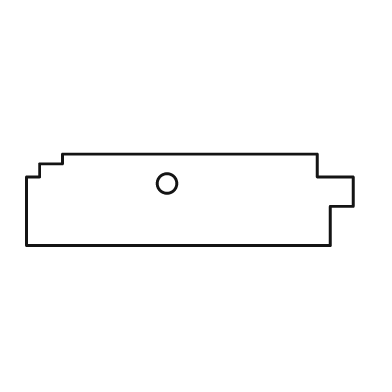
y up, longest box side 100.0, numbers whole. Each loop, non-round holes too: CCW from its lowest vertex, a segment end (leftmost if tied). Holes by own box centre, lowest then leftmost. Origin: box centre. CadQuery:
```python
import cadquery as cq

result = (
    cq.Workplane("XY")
    .moveTo(-50.0, -14.0)
    .lineTo(43.0, -14.0)
    .lineTo(43.0, -2.0)
    .lineTo(50.0, -2.0)
    .lineTo(50.0, 7.0)
    .lineTo(39.0, 7.0)
    .lineTo(39.0, 14.0)
    .lineTo(-39.0, 14.0)
    .lineTo(-39.0, 11.0)
    .lineTo(-46.0, 11.0)
    .lineTo(-46.0, 7.0)
    .lineTo(-50.0, 7.0)
    .close()
    .moveTo(-7.0, 5.0)
    .circle(3.0)
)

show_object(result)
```